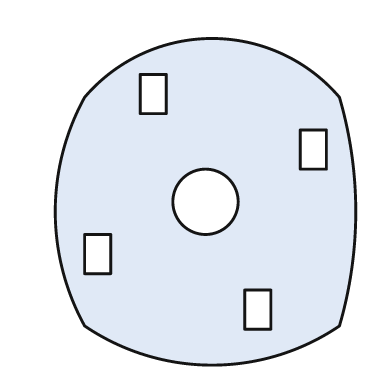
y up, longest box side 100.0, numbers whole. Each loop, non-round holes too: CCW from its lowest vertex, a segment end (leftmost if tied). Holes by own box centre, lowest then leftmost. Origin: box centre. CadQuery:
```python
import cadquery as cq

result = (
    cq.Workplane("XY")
    .moveTo(-37.0, -38.0)
    .threePointArc((2.0, -50.0), (41.0, -38.0))
    .threePointArc((46.0, -3.0), (41.0, 32.0))
    .threePointArc((2.0, 50.0), (-37.0, 32.0))
    .threePointArc((-46.0, -3.0), (-37.0, -38.0))
    .close()
    .moveTo(12.0, -39.0)
    .lineTo(20.0, -39.0)
    .lineTo(20.0, -27.0)
    .lineTo(12.0, -27.0)
    .close()
    .moveTo(-37.0, -22.0)
    .lineTo(-29.0, -22.0)
    .lineTo(-29.0, -10.0)
    .lineTo(-37.0, -10.0)
    .close()
    .moveTo(0.0, 0.0)
    .circle(10.0)
    .moveTo(29.0, 10.0)
    .lineTo(37.0, 10.0)
    .lineTo(37.0, 22.0)
    .lineTo(29.0, 22.0)
    .close()
    .moveTo(-20.0, 27.0)
    .lineTo(-12.0, 27.0)
    .lineTo(-12.0, 39.0)
    .lineTo(-20.0, 39.0)
    .close()
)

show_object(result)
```